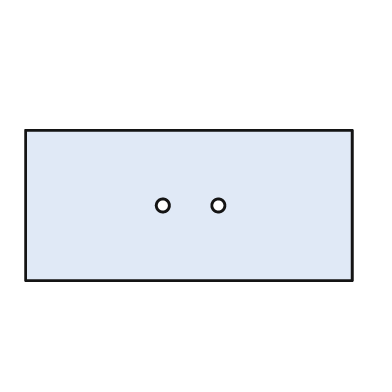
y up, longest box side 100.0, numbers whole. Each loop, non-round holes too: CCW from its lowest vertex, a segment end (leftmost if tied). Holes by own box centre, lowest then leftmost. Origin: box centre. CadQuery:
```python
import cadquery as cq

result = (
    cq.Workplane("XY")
    .moveTo(-50.0, -23.0)
    .lineTo(50.0, -23.0)
    .lineTo(50.0, 23.0)
    .lineTo(-50.0, 23.0)
    .close()
    .moveTo(-8.0, 0.0)
    .circle(2.0)
    .moveTo(9.0, 0.0)
    .circle(2.0)
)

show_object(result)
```